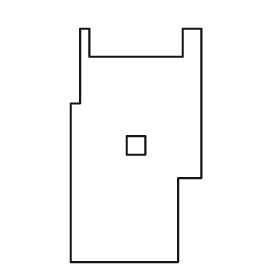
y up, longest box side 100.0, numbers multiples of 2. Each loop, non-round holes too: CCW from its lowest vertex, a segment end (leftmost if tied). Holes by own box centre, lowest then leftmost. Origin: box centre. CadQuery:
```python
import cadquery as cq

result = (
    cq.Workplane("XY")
    .moveTo(-28.0, -50.0)
    .lineTo(18.0, -50.0)
    .lineTo(18.0, -14.0)
    .lineTo(28.0, -14.0)
    .lineTo(28.0, 50.0)
    .lineTo(20.0, 50.0)
    .lineTo(20.0, 38.0)
    .lineTo(-20.0, 38.0)
    .lineTo(-20.0, 50.0)
    .lineTo(-24.0, 50.0)
    .lineTo(-24.0, 18.0)
    .lineTo(-28.0, 18.0)
    .close()
    .moveTo(-4.0, -4.0)
    .lineTo(4.0, -4.0)
    .lineTo(4.0, 4.0)
    .lineTo(-4.0, 4.0)
    .close()
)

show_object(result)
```